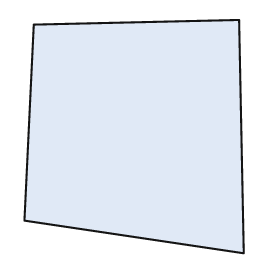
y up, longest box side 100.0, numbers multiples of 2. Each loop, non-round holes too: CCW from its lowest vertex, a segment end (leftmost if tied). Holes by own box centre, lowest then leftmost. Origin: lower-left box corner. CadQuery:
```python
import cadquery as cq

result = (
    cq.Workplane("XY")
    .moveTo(94.0, 0.0)
    .lineTo(92.0, 100.0)
    .lineTo(4.0, 98.0)
    .lineTo(0.0, 14.0)
    .close()
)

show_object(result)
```